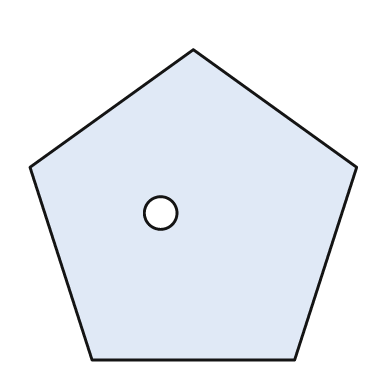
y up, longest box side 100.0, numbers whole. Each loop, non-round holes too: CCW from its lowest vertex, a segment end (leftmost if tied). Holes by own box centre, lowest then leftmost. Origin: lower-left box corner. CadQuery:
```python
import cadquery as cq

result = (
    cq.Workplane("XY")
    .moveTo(19.0, 0.0)
    .lineTo(81.0, 0.0)
    .lineTo(100.0, 59.0)
    .lineTo(50.0, 95.0)
    .lineTo(0.0, 59.0)
    .close()
    .moveTo(40.0, 45.0)
    .circle(5.0)
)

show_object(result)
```